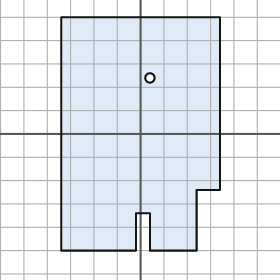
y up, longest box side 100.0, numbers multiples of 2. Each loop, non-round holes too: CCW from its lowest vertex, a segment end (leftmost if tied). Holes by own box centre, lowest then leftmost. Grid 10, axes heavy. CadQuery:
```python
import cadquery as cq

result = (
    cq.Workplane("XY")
    .moveTo(-34.0, -50.0)
    .lineTo(-2.0, -50.0)
    .lineTo(-2.0, -34.0)
    .lineTo(4.0, -34.0)
    .lineTo(4.0, -50.0)
    .lineTo(24.0, -50.0)
    .lineTo(24.0, -24.0)
    .lineTo(34.0, -24.0)
    .lineTo(34.0, 50.0)
    .lineTo(-34.0, 50.0)
    .close()
    .moveTo(4.0, 24.0)
    .circle(2.0)
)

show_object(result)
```